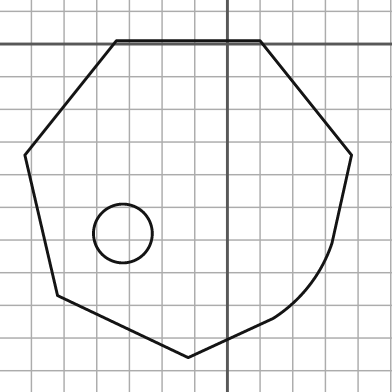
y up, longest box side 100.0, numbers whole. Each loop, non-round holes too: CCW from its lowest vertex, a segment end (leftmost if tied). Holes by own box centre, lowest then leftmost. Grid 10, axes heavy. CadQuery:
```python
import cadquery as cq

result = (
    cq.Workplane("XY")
    .moveTo(-12.0, -96.0)
    .lineTo(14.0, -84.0)
    .threePointArc((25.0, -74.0), (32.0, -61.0))
    .lineTo(38.0, -34.0)
    .lineTo(10.0, 1.0)
    .lineTo(-34.0, 1.0)
    .lineTo(-62.0, -34.0)
    .lineTo(-52.0, -77.0)
    .close()
    .moveTo(-32.0, -58.0)
    .circle(9.0)
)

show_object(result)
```